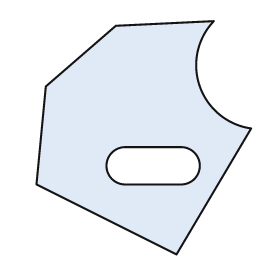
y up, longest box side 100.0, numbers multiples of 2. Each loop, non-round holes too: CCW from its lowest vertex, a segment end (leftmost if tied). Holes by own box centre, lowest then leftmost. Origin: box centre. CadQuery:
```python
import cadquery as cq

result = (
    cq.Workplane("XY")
    .moveTo(14.0, -50.0)
    .lineTo(46.0, 4.0)
    .threePointArc((24.0, 22.0), (30.0, 50.0))
    .lineTo(-12.0, 48.0)
    .lineTo(-42.0, 22.0)
    .lineTo(-46.0, -20.0)
    .close()
    .moveTo(-8.0, -20.0)
    .lineTo(16.0, -20.0)
    .threePointArc((24.0, -12.0), (16.0, -4.0))
    .lineTo(-8.0, -4.0)
    .threePointArc((-16.0, -12.0), (-8.0, -20.0))
    .close()
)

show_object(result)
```